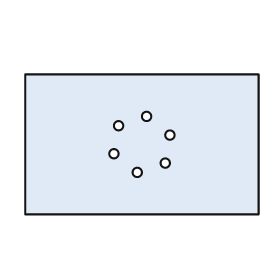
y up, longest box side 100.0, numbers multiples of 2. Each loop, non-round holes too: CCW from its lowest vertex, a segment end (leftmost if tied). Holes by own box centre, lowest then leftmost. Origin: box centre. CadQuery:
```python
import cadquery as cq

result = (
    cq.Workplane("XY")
    .moveTo(-50.0, -30.0)
    .lineTo(50.0, -30.0)
    .lineTo(50.0, 30.0)
    .lineTo(-50.0, 30.0)
    .close()
    .moveTo(-2.0, -12.0)
    .circle(2.0)
    .moveTo(10.0, -8.0)
    .circle(2.0)
    .moveTo(-12.0, -4.0)
    .circle(2.0)
    .moveTo(12.0, 4.0)
    .circle(2.0)
    .moveTo(-10.0, 8.0)
    .circle(2.0)
    .moveTo(2.0, 12.0)
    .circle(2.0)
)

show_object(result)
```